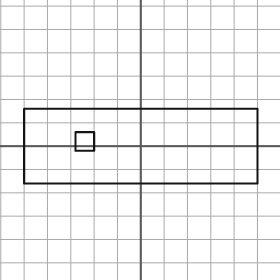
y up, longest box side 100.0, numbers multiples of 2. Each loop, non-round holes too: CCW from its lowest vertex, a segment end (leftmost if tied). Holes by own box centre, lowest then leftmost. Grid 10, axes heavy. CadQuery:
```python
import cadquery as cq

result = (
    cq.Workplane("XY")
    .moveTo(-50.0, -16.0)
    .lineTo(50.0, -16.0)
    .lineTo(50.0, 16.0)
    .lineTo(-50.0, 16.0)
    .close()
    .moveTo(-28.0, -2.0)
    .lineTo(-20.0, -2.0)
    .lineTo(-20.0, 6.0)
    .lineTo(-28.0, 6.0)
    .close()
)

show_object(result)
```